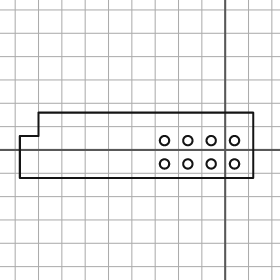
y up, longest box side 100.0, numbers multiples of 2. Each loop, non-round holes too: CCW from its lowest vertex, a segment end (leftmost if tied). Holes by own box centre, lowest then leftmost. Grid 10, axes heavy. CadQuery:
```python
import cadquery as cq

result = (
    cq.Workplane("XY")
    .moveTo(-88.0, -12.0)
    .lineTo(12.0, -12.0)
    .lineTo(12.0, 16.0)
    .lineTo(-80.0, 16.0)
    .lineTo(-80.0, 6.0)
    .lineTo(-88.0, 6.0)
    .close()
    .moveTo(-26.0, -6.0)
    .circle(2.0)
    .moveTo(-16.0, -6.0)
    .circle(2.0)
    .moveTo(-6.0, -6.0)
    .circle(2.0)
    .moveTo(4.0, -6.0)
    .circle(2.0)
    .moveTo(-26.0, 4.0)
    .circle(2.0)
    .moveTo(-16.0, 4.0)
    .circle(2.0)
    .moveTo(-6.0, 4.0)
    .circle(2.0)
    .moveTo(4.0, 4.0)
    .circle(2.0)
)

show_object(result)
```